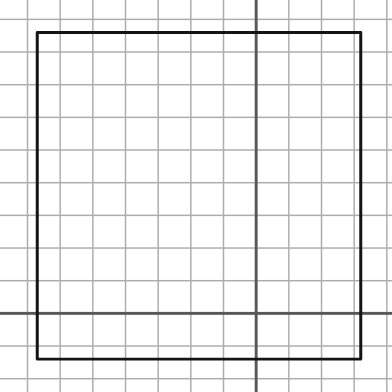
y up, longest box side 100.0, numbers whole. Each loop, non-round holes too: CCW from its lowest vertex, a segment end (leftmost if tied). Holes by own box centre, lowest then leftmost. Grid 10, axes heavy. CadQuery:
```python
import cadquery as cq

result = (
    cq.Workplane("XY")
    .moveTo(-67.0, -14.0)
    .lineTo(32.0, -14.0)
    .lineTo(32.0, 86.0)
    .lineTo(-67.0, 86.0)
    .close()
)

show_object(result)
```